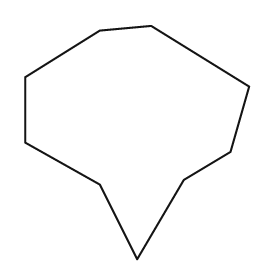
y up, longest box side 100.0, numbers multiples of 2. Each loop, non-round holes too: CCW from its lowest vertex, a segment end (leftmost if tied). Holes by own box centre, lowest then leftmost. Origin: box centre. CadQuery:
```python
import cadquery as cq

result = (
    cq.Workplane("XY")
    .moveTo(0.0, -50.0)
    .lineTo(20.0, -16.0)
    .lineTo(40.0, -4.0)
    .lineTo(48.0, 24.0)
    .lineTo(6.0, 50.0)
    .lineTo(-16.0, 48.0)
    .lineTo(-48.0, 28.0)
    .lineTo(-48.0, 0.0)
    .lineTo(-16.0, -18.0)
    .close()
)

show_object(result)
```